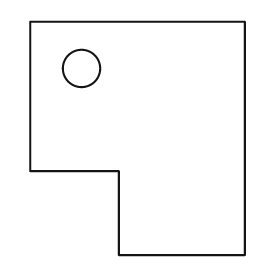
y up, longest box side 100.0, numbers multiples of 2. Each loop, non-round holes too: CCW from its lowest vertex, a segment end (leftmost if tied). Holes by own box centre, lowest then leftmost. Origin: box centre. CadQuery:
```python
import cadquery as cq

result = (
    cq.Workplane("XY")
    .moveTo(-8.0, -50.0)
    .lineTo(46.0, -50.0)
    .lineTo(46.0, 50.0)
    .lineTo(-46.0, 50.0)
    .lineTo(-46.0, -14.0)
    .lineTo(-8.0, -14.0)
    .close()
    .moveTo(-24.0, 30.0)
    .circle(8.0)
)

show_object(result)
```